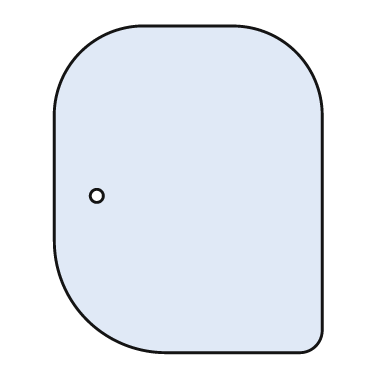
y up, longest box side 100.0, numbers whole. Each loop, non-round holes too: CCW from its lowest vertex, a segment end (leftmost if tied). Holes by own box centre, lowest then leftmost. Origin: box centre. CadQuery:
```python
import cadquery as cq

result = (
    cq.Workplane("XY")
    .moveTo(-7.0, -50.0)
    .lineTo(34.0, -50.0)
    .threePointArc((39.0, -48.0), (41.0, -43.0))
    .lineTo(41.0, 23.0)
    .threePointArc((33.0, 42.0), (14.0, 50.0))
    .lineTo(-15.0, 50.0)
    .threePointArc((-33.0, 42.0), (-41.0, 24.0))
    .lineTo(-41.0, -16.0)
    .threePointArc((-31.0, -40.0), (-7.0, -50.0))
    .close()
    .moveTo(-28.0, -2.0)
    .circle(2.0)
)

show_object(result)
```